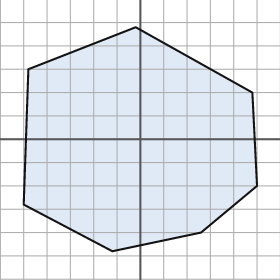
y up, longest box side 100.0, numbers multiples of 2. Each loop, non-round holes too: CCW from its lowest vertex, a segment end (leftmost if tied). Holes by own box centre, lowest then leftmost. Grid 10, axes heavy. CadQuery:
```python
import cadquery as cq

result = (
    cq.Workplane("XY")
    .moveTo(-12.0, -48.0)
    .lineTo(26.0, -40.0)
    .lineTo(50.0, -20.0)
    .lineTo(48.0, 20.0)
    .lineTo(-2.0, 48.0)
    .lineTo(-48.0, 30.0)
    .lineTo(-50.0, -28.0)
    .close()
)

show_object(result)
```